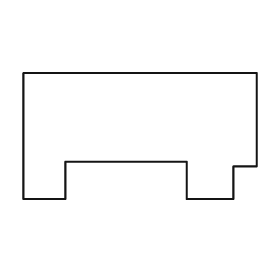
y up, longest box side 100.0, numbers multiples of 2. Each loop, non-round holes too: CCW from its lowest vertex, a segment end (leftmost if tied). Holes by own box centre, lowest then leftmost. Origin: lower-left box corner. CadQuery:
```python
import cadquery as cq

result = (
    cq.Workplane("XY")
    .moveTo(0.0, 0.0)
    .lineTo(18.0, 0.0)
    .lineTo(18.0, 16.0)
    .lineTo(70.0, 16.0)
    .lineTo(70.0, 0.0)
    .lineTo(90.0, 0.0)
    .lineTo(90.0, 14.0)
    .lineTo(100.0, 14.0)
    .lineTo(100.0, 54.0)
    .lineTo(0.0, 54.0)
    .close()
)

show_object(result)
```